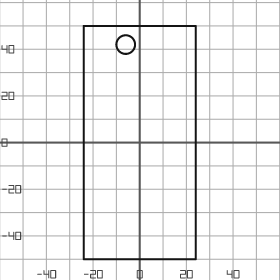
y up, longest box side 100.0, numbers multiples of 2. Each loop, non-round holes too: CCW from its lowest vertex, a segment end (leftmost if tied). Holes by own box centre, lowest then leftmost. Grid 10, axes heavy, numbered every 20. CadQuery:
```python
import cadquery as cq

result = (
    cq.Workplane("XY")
    .moveTo(-24.0, -50.0)
    .lineTo(24.0, -50.0)
    .lineTo(24.0, 50.0)
    .lineTo(-24.0, 50.0)
    .close()
    .moveTo(-6.0, 42.0)
    .circle(4.0)
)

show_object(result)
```